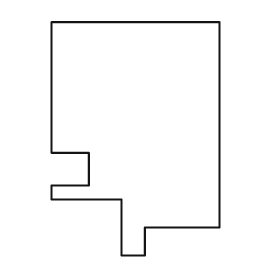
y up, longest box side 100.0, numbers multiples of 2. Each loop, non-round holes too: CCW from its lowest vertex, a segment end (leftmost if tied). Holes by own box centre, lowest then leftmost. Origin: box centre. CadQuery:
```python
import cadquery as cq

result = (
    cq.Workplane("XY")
    .moveTo(-6.0, -50.0)
    .lineTo(4.0, -50.0)
    .lineTo(4.0, -38.0)
    .lineTo(36.0, -38.0)
    .lineTo(36.0, 50.0)
    .lineTo(-36.0, 50.0)
    .lineTo(-36.0, -6.0)
    .lineTo(-20.0, -6.0)
    .lineTo(-20.0, -20.0)
    .lineTo(-36.0, -20.0)
    .lineTo(-36.0, -26.0)
    .lineTo(-6.0, -26.0)
    .close()
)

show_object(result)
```